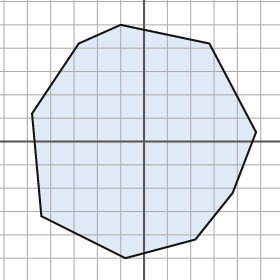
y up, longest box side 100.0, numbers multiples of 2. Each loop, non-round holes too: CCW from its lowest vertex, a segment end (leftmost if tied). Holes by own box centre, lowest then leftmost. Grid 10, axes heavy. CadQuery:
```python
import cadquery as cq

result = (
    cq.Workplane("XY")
    .moveTo(-8.0, -50.0)
    .lineTo(22.0, -42.0)
    .lineTo(38.0, -22.0)
    .lineTo(48.0, 4.0)
    .lineTo(28.0, 42.0)
    .lineTo(-10.0, 50.0)
    .lineTo(-28.0, 42.0)
    .lineTo(-48.0, 12.0)
    .lineTo(-44.0, -32.0)
    .close()
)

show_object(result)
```